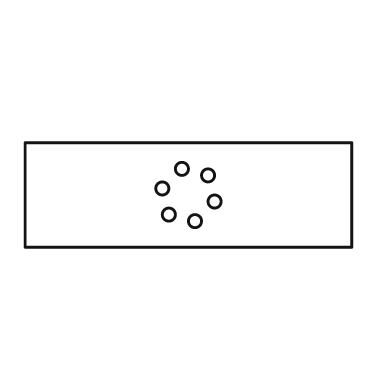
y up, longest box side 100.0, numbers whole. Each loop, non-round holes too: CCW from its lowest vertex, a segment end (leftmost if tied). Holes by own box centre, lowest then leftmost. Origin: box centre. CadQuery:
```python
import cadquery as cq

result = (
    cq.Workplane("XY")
    .moveTo(-50.0, -16.0)
    .lineTo(50.0, -16.0)
    .lineTo(50.0, 16.0)
    .lineTo(-50.0, 16.0)
    .close()
    .moveTo(2.0, -8.0)
    .circle(2.0)
    .moveTo(-6.0, -6.0)
    .circle(2.0)
    .moveTo(8.0, -2.0)
    .circle(2.0)
    .moveTo(-8.0, 2.0)
    .circle(2.0)
    .moveTo(6.0, 6.0)
    .circle(2.0)
    .moveTo(-2.0, 8.0)
    .circle(2.0)
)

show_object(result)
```